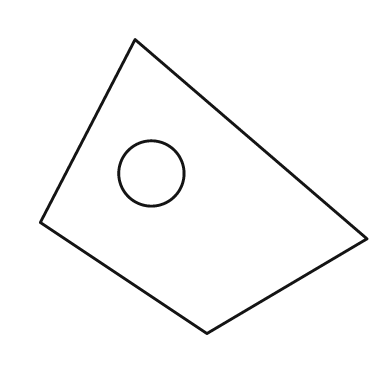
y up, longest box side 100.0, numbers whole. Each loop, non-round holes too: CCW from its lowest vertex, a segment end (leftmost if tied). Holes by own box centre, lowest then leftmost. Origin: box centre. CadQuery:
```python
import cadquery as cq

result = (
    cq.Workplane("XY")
    .moveTo(1.0, -45.0)
    .lineTo(50.0, -16.0)
    .lineTo(-21.0, 45.0)
    .lineTo(-50.0, -11.0)
    .close()
    .moveTo(-16.0, 4.0)
    .circle(10.0)
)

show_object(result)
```